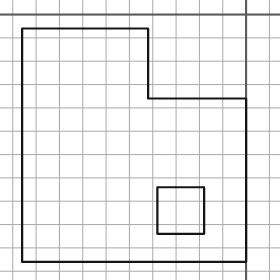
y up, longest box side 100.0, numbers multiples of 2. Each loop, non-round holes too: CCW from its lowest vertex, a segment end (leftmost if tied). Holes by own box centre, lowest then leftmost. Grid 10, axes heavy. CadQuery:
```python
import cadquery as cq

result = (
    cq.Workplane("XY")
    .moveTo(-96.0, -106.0)
    .lineTo(0.0, -106.0)
    .lineTo(0.0, -36.0)
    .lineTo(-42.0, -36.0)
    .lineTo(-42.0, -6.0)
    .lineTo(-96.0, -6.0)
    .close()
    .moveTo(-38.0, -94.0)
    .lineTo(-18.0, -94.0)
    .lineTo(-18.0, -74.0)
    .lineTo(-38.0, -74.0)
    .close()
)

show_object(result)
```